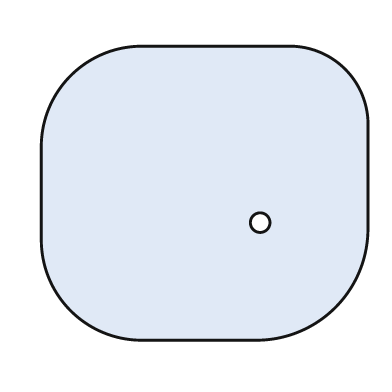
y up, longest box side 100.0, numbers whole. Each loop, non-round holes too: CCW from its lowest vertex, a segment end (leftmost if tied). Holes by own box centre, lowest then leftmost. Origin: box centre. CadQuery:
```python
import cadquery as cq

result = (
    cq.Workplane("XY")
    .moveTo(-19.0, -45.0)
    .lineTo(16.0, -45.0)
    .threePointArc((40.0, -35.0), (50.0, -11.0))
    .lineTo(50.0, 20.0)
    .threePointArc((43.0, 38.0), (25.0, 45.0))
    .lineTo(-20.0, 45.0)
    .threePointArc((-41.0, 36.0), (-50.0, 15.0))
    .lineTo(-50.0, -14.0)
    .threePointArc((-41.0, -36.0), (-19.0, -45.0))
    .close()
    .moveTo(17.0, -9.0)
    .circle(3.0)
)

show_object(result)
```